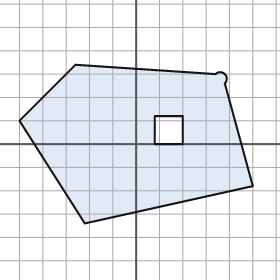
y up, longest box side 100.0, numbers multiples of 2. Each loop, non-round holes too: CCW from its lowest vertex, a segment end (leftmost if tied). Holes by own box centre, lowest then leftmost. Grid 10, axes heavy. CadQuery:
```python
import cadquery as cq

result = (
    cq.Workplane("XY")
    .moveTo(-22.0, -34.0)
    .lineTo(50.0, -18.0)
    .lineTo(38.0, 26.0)
    .threePointArc((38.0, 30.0), (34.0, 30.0))
    .lineTo(-26.0, 34.0)
    .lineTo(-50.0, 10.0)
    .close()
    .moveTo(8.0, 0.0)
    .lineTo(20.0, 0.0)
    .lineTo(20.0, 12.0)
    .lineTo(8.0, 12.0)
    .close()
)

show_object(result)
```